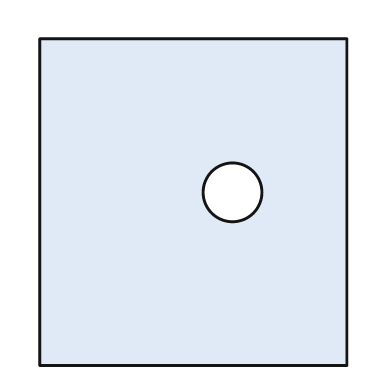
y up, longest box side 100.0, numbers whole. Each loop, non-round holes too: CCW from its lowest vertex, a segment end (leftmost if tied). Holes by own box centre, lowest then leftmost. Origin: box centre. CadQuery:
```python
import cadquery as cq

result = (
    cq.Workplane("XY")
    .moveTo(-47.0, -50.0)
    .lineTo(47.0, -50.0)
    .lineTo(47.0, 50.0)
    .lineTo(-47.0, 50.0)
    .close()
    .moveTo(12.0, 3.0)
    .circle(9.0)
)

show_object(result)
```